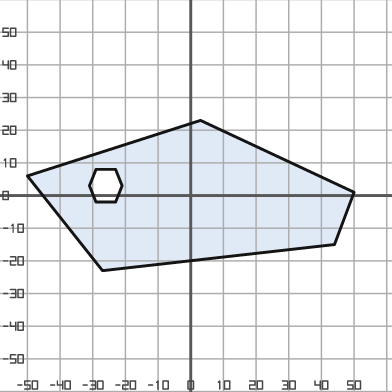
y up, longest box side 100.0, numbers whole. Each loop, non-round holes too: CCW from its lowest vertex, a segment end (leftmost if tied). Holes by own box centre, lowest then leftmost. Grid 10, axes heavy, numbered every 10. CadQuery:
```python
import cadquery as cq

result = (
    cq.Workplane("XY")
    .moveTo(-27.0, -23.0)
    .lineTo(44.0, -15.0)
    .lineTo(50.0, 1.0)
    .lineTo(3.0, 23.0)
    .lineTo(-50.0, 6.0)
    .close()
    .moveTo(-29.0, -2.0)
    .lineTo(-23.0, -2.0)
    .lineTo(-21.0, 3.0)
    .lineTo(-23.0, 8.0)
    .lineTo(-29.0, 8.0)
    .lineTo(-31.0, 3.0)
    .close()
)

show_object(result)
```